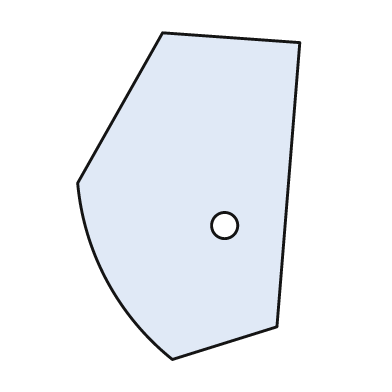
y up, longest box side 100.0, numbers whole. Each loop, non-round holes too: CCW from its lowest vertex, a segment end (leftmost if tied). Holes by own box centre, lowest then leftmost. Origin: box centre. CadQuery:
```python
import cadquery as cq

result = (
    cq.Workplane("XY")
    .moveTo(-5.0, -50.0)
    .lineTo(27.0, -40.0)
    .lineTo(34.0, 47.0)
    .lineTo(-8.0, 50.0)
    .lineTo(-34.0, 4.0)
    .threePointArc((-25.0, -26.0), (-5.0, -50.0))
    .close()
    .moveTo(11.0, -9.0)
    .circle(4.0)
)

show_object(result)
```